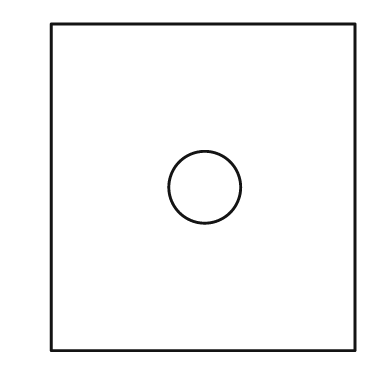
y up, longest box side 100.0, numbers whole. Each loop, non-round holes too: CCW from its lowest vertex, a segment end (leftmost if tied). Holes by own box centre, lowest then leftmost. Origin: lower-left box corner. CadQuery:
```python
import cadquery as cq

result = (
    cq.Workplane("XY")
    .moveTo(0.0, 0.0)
    .lineTo(93.0, 0.0)
    .lineTo(93.0, 100.0)
    .lineTo(0.0, 100.0)
    .close()
    .moveTo(47.0, 50.0)
    .circle(11.0)
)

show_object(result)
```